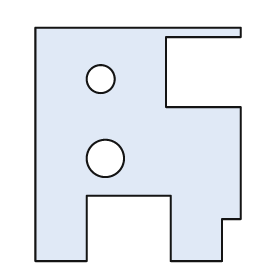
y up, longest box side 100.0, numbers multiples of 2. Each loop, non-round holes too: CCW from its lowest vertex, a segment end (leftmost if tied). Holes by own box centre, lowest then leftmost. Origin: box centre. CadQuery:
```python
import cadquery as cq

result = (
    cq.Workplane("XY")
    .moveTo(-44.0, -50.0)
    .lineTo(-22.0, -50.0)
    .lineTo(-22.0, -22.0)
    .lineTo(14.0, -22.0)
    .lineTo(14.0, -50.0)
    .lineTo(36.0, -50.0)
    .lineTo(36.0, -32.0)
    .lineTo(44.0, -32.0)
    .lineTo(44.0, 16.0)
    .lineTo(12.0, 16.0)
    .lineTo(12.0, 46.0)
    .lineTo(44.0, 46.0)
    .lineTo(44.0, 50.0)
    .lineTo(-44.0, 50.0)
    .close()
    .moveTo(-14.0, -6.0)
    .circle(8.0)
    .moveTo(-16.0, 28.0)
    .circle(6.0)
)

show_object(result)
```